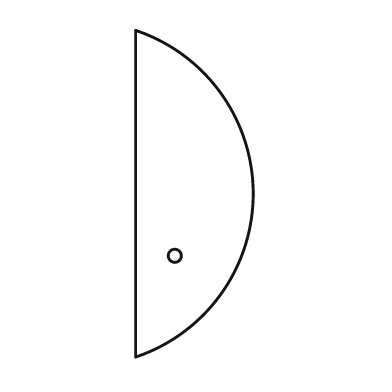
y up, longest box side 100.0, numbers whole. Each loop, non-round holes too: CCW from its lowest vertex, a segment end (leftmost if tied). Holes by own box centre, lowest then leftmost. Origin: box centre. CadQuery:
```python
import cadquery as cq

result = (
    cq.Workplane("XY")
    .moveTo(-18.0, -50.0)
    .threePointArc((18.0, 0.0), (-18.0, 50.0))
    .close()
    .moveTo(-6.0, -19.0)
    .circle(2.0)
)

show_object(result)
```